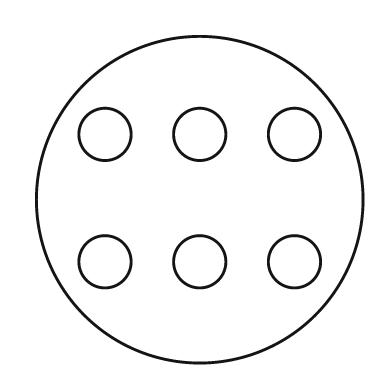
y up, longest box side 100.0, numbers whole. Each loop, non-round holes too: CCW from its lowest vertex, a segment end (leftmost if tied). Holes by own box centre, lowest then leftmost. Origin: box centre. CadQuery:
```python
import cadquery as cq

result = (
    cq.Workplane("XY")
    .moveTo(0.0, 0.0)
    .circle(50.0)
    .moveTo(-29.0, -19.0)
    .circle(8.0)
    .moveTo(0.0, -19.0)
    .circle(8.0)
    .moveTo(29.0, -19.0)
    .circle(8.0)
    .moveTo(-29.0, 20.0)
    .circle(8.0)
    .moveTo(0.0, 20.0)
    .circle(8.0)
    .moveTo(29.0, 20.0)
    .circle(8.0)
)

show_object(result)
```